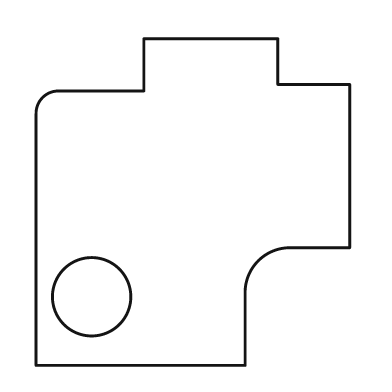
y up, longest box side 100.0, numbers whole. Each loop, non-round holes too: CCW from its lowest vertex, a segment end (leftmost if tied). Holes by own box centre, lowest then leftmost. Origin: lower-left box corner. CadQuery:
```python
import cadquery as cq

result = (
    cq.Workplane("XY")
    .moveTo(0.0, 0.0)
    .lineTo(64.0, 0.0)
    .lineTo(64.0, 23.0)
    .threePointArc((68.0, 32.0), (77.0, 36.0))
    .lineTo(96.0, 36.0)
    .lineTo(96.0, 86.0)
    .lineTo(74.0, 86.0)
    .lineTo(74.0, 100.0)
    .lineTo(33.0, 100.0)
    .lineTo(33.0, 84.0)
    .lineTo(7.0, 84.0)
    .threePointArc((2.0, 82.0), (0.0, 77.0))
    .close()
    .moveTo(17.0, 21.0)
    .circle(12.0)
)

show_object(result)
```